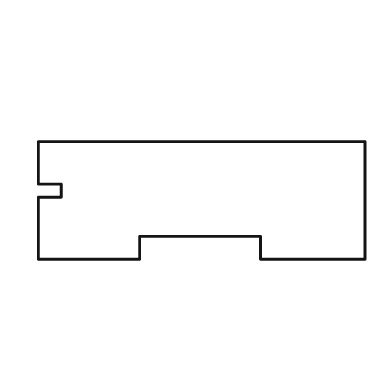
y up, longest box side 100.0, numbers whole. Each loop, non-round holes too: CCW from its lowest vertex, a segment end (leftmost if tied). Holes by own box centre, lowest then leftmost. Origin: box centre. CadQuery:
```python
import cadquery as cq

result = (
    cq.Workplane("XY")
    .moveTo(-50.0, -18.0)
    .lineTo(-19.0, -18.0)
    .lineTo(-19.0, -11.0)
    .lineTo(18.0, -11.0)
    .lineTo(18.0, -18.0)
    .lineTo(50.0, -18.0)
    .lineTo(50.0, 18.0)
    .lineTo(-50.0, 18.0)
    .lineTo(-50.0, 5.0)
    .lineTo(-43.0, 5.0)
    .lineTo(-43.0, 1.0)
    .lineTo(-50.0, 1.0)
    .close()
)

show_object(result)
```